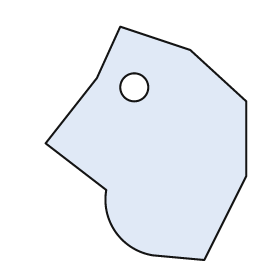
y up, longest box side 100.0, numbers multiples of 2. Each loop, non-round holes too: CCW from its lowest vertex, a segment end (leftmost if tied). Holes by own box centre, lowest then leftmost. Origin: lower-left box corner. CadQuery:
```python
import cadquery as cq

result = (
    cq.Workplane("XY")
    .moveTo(68.0, 0.0)
    .lineTo(86.0, 36.0)
    .lineTo(86.0, 68.0)
    .lineTo(62.0, 90.0)
    .lineTo(32.0, 100.0)
    .lineTo(22.0, 78.0)
    .lineTo(0.0, 50.0)
    .lineTo(26.0, 30.0)
    .threePointArc((30.0, 12.0), (46.0, 2.0))
    .close()
    .moveTo(38.0, 74.0)
    .circle(6.0)
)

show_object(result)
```